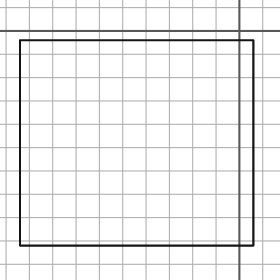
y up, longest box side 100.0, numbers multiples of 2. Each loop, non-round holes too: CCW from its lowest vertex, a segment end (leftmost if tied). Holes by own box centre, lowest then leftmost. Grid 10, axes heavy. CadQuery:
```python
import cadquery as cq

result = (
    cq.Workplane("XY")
    .moveTo(-94.0, -92.0)
    .lineTo(6.0, -92.0)
    .lineTo(6.0, -4.0)
    .lineTo(-94.0, -4.0)
    .close()
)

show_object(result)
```